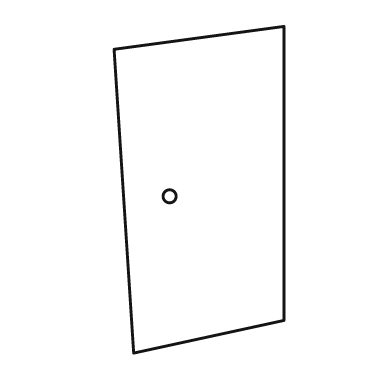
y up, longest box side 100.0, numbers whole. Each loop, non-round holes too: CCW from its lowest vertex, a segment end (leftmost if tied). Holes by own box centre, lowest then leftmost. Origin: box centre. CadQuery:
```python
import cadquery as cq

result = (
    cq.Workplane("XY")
    .moveTo(-20.0, -50.0)
    .lineTo(26.0, -40.0)
    .lineTo(26.0, 50.0)
    .lineTo(-26.0, 43.0)
    .close()
    .moveTo(-9.0, -2.0)
    .circle(2.0)
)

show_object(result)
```